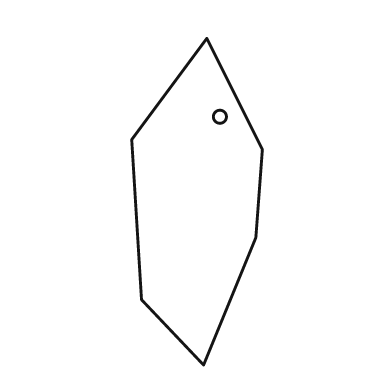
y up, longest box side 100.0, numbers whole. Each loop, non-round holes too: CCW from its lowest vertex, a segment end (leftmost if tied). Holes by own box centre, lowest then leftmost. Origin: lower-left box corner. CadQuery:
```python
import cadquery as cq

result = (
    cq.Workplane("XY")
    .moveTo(22.0, 0.0)
    .lineTo(38.0, 39.0)
    .lineTo(40.0, 66.0)
    .lineTo(23.0, 100.0)
    .lineTo(0.0, 69.0)
    .lineTo(3.0, 20.0)
    .close()
    .moveTo(27.0, 76.0)
    .circle(2.0)
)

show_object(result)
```